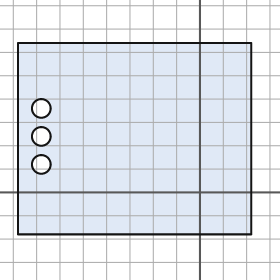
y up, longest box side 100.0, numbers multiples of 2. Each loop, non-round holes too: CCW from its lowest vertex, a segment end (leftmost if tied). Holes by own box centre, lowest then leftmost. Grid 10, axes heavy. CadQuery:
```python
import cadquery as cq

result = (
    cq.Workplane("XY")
    .moveTo(-78.0, -18.0)
    .lineTo(22.0, -18.0)
    .lineTo(22.0, 64.0)
    .lineTo(-78.0, 64.0)
    .close()
    .moveTo(-68.0, 12.0)
    .circle(4.0)
    .moveTo(-68.0, 24.0)
    .circle(4.0)
    .moveTo(-68.0, 36.0)
    .circle(4.0)
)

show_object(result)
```